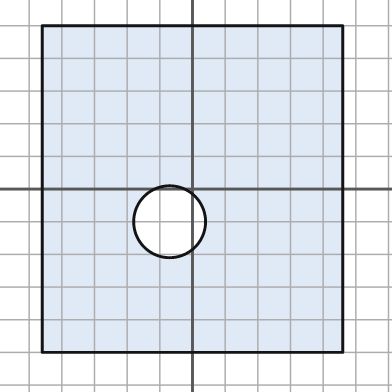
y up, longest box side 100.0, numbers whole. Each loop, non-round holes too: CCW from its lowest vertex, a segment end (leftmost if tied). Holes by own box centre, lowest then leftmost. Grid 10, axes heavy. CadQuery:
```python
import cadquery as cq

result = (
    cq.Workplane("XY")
    .moveTo(-46.0, -50.0)
    .lineTo(46.0, -50.0)
    .lineTo(46.0, 50.0)
    .lineTo(-46.0, 50.0)
    .close()
    .moveTo(-7.0, -10.0)
    .circle(11.0)
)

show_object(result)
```